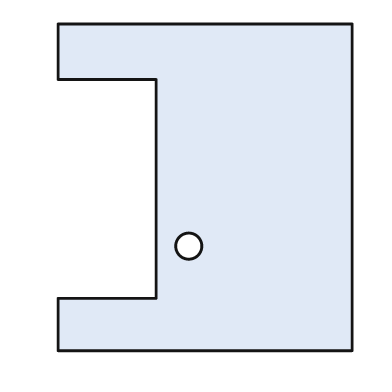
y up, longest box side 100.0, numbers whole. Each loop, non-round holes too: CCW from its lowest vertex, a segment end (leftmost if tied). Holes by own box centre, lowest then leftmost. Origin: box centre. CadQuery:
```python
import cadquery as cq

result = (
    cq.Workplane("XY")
    .moveTo(-45.0, -50.0)
    .lineTo(45.0, -50.0)
    .lineTo(45.0, 50.0)
    .lineTo(-45.0, 50.0)
    .lineTo(-45.0, 33.0)
    .lineTo(-15.0, 33.0)
    .lineTo(-15.0, -34.0)
    .lineTo(-45.0, -34.0)
    .close()
    .moveTo(-5.0, -18.0)
    .circle(4.0)
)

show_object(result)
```